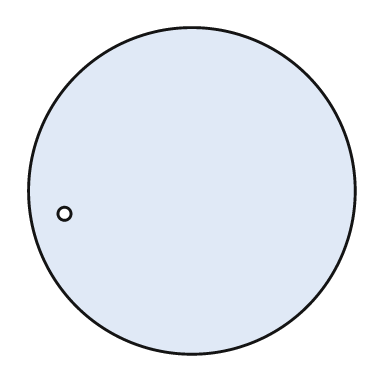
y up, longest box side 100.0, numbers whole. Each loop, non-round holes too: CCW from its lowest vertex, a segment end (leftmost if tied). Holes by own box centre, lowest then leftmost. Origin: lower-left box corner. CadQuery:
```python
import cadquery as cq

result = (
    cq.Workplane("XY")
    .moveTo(50.0, 50.0)
    .circle(50.0)
    .moveTo(11.0, 43.0)
    .circle(2.0)
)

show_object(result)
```